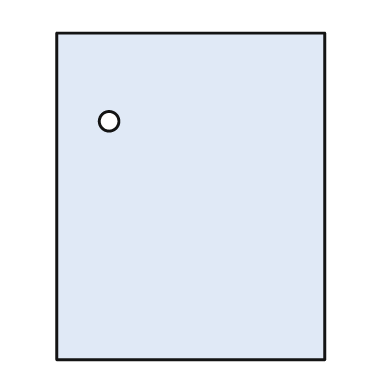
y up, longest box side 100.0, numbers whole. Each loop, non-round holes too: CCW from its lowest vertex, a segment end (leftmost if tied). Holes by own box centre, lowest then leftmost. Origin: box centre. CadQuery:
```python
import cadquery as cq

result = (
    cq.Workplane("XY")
    .moveTo(-41.0, -50.0)
    .lineTo(41.0, -50.0)
    .lineTo(41.0, 50.0)
    .lineTo(-41.0, 50.0)
    .close()
    .moveTo(-25.0, 23.0)
    .circle(3.0)
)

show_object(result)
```